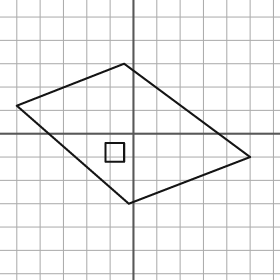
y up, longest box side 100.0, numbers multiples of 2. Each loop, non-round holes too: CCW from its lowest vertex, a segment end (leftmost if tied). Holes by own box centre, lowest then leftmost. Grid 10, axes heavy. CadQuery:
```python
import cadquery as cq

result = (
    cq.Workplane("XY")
    .moveTo(-2.0, -30.0)
    .lineTo(50.0, -10.0)
    .lineTo(-4.0, 30.0)
    .lineTo(-50.0, 12.0)
    .close()
    .moveTo(-12.0, -12.0)
    .lineTo(-4.0, -12.0)
    .lineTo(-4.0, -4.0)
    .lineTo(-12.0, -4.0)
    .close()
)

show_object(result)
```